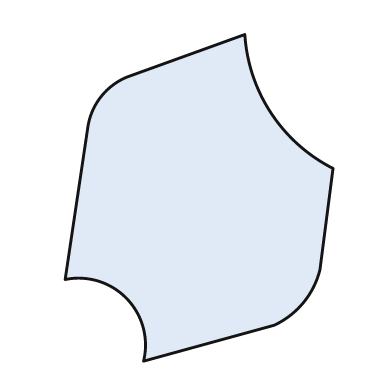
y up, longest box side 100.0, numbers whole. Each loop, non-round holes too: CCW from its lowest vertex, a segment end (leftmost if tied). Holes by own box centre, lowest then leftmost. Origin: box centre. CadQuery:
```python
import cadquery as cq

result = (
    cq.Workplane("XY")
    .moveTo(-17.0, -50.0)
    .lineTo(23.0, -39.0)
    .threePointArc((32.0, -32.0), (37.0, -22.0))
    .lineTo(41.0, 9.0)
    .threePointArc((22.0, 26.0), (14.0, 50.0))
    .lineTo(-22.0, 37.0)
    .threePointArc((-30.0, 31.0), (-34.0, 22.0))
    .lineTo(-41.0, -25.0)
    .threePointArc((-22.0, -31.0), (-17.0, -50.0))
    .close()
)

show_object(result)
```